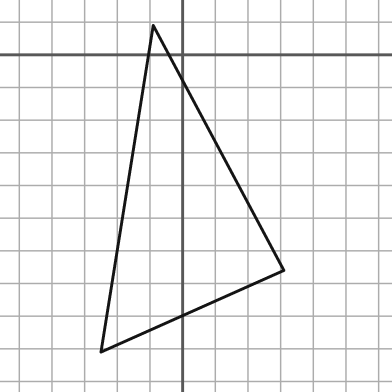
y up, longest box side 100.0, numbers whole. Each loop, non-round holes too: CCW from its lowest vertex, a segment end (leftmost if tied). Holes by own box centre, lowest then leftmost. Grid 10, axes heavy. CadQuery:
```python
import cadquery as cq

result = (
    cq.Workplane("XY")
    .moveTo(-25.0, -91.0)
    .lineTo(31.0, -66.0)
    .lineTo(-9.0, 9.0)
    .close()
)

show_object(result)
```